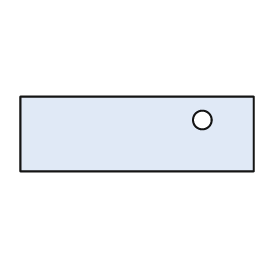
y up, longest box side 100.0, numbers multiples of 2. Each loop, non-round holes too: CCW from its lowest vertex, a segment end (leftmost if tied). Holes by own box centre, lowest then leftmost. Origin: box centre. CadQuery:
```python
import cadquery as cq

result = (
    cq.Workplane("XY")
    .moveTo(-50.0, -16.0)
    .lineTo(50.0, -16.0)
    .lineTo(50.0, 16.0)
    .lineTo(-50.0, 16.0)
    .close()
    .moveTo(28.0, 6.0)
    .circle(4.0)
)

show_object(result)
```